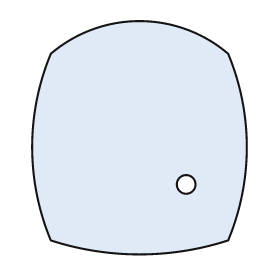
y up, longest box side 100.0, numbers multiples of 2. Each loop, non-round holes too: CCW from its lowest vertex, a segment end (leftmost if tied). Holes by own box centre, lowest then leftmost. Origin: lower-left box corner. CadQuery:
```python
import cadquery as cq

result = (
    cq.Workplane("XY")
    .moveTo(8.0, 6.0)
    .threePointArc((46.0, 0.0), (84.0, 6.0))
    .threePointArc((92.0, 46.0), (84.0, 86.0))
    .threePointArc((46.0, 100.0), (8.0, 86.0))
    .threePointArc((0.0, 46.0), (8.0, 6.0))
    .close()
    .moveTo(66.0, 30.0)
    .circle(4.0)
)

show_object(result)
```